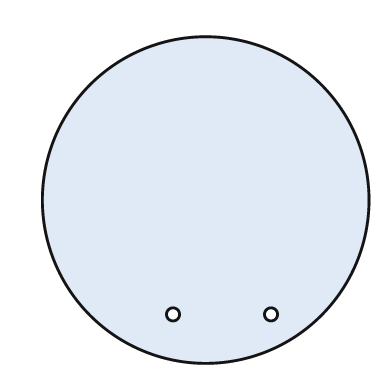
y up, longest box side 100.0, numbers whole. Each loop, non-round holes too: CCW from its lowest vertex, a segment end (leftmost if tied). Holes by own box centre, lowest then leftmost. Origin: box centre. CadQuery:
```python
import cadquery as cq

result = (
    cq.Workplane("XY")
    .moveTo(0.0, 0.0)
    .circle(50.0)
    .moveTo(-10.0, -35.0)
    .circle(2.0)
    .moveTo(20.0, -35.0)
    .circle(2.0)
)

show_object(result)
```